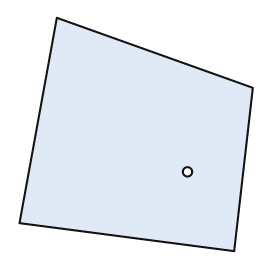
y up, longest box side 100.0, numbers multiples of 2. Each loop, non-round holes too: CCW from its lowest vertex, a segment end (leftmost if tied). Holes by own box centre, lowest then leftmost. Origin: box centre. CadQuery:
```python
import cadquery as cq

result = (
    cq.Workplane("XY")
    .moveTo(42.0, -50.0)
    .lineTo(50.0, 20.0)
    .lineTo(-34.0, 50.0)
    .lineTo(-50.0, -38.0)
    .close()
    .moveTo(22.0, -16.0)
    .circle(2.0)
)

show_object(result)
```